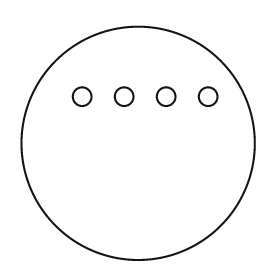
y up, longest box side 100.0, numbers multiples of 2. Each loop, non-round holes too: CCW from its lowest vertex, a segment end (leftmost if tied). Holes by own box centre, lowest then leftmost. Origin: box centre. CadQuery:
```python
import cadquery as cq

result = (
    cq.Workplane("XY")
    .moveTo(0.0, 0.0)
    .circle(50.0)
    .moveTo(-24.0, 20.0)
    .circle(4.0)
    .moveTo(-6.0, 20.0)
    .circle(4.0)
    .moveTo(12.0, 20.0)
    .circle(4.0)
    .moveTo(30.0, 20.0)
    .circle(4.0)
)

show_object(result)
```